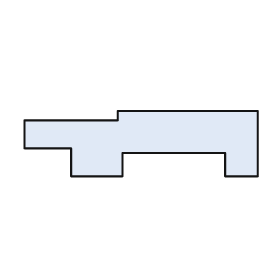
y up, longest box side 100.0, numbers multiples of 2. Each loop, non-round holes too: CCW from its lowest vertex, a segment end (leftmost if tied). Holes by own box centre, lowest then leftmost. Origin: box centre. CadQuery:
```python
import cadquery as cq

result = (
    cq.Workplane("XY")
    .moveTo(-30.0, -14.0)
    .lineTo(-8.0, -14.0)
    .lineTo(-8.0, -4.0)
    .lineTo(36.0, -4.0)
    .lineTo(36.0, -14.0)
    .lineTo(50.0, -14.0)
    .lineTo(50.0, 14.0)
    .lineTo(-10.0, 14.0)
    .lineTo(-10.0, 10.0)
    .lineTo(-50.0, 10.0)
    .lineTo(-50.0, -2.0)
    .lineTo(-30.0, -2.0)
    .close()
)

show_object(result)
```